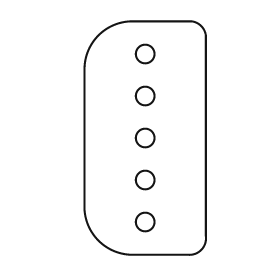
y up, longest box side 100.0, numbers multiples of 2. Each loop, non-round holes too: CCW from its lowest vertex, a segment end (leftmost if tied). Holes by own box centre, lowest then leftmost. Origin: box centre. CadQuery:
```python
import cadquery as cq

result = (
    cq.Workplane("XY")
    .moveTo(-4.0, -50.0)
    .lineTo(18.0, -50.0)
    .threePointArc((24.0, -48.0), (26.0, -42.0))
    .lineTo(26.0, 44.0)
    .threePointArc((24.0, 48.0), (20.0, 50.0))
    .lineTo(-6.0, 50.0)
    .threePointArc((-20.0, 44.0), (-26.0, 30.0))
    .lineTo(-26.0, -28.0)
    .threePointArc((-20.0, -44.0), (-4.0, -50.0))
    .close()
    .moveTo(0.0, -36.0)
    .circle(4.0)
    .moveTo(0.0, -18.0)
    .circle(4.0)
    .moveTo(0.0, 0.0)
    .circle(4.0)
    .moveTo(0.0, 18.0)
    .circle(4.0)
    .moveTo(0.0, 36.0)
    .circle(4.0)
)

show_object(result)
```